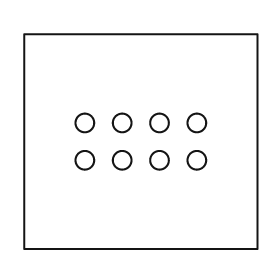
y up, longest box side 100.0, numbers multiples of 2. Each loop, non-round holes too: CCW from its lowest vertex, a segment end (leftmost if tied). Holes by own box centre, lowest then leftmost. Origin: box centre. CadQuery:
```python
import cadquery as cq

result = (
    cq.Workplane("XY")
    .moveTo(-50.0, -46.0)
    .lineTo(50.0, -46.0)
    .lineTo(50.0, 46.0)
    .lineTo(-50.0, 46.0)
    .close()
    .moveTo(-24.0, -8.0)
    .circle(4.0)
    .moveTo(-8.0, -8.0)
    .circle(4.0)
    .moveTo(8.0, -8.0)
    .circle(4.0)
    .moveTo(24.0, -8.0)
    .circle(4.0)
    .moveTo(-24.0, 8.0)
    .circle(4.0)
    .moveTo(-8.0, 8.0)
    .circle(4.0)
    .moveTo(8.0, 8.0)
    .circle(4.0)
    .moveTo(24.0, 8.0)
    .circle(4.0)
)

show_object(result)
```